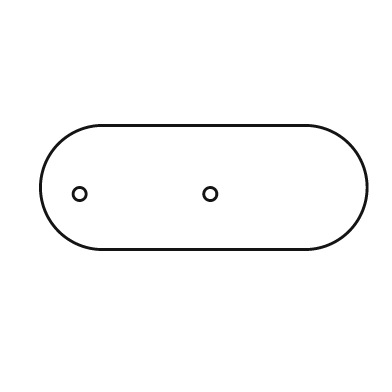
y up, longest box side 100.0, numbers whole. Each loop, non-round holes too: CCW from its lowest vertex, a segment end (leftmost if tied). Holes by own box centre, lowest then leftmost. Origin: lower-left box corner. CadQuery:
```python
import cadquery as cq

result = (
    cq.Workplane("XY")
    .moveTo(19.0, 0.0)
    .lineTo(81.0, 0.0)
    .threePointArc((100.0, 19.0), (81.0, 38.0))
    .lineTo(19.0, 38.0)
    .threePointArc((0.0, 19.0), (19.0, 0.0))
    .close()
    .moveTo(12.0, 17.0)
    .circle(2.0)
    .moveTo(52.0, 17.0)
    .circle(2.0)
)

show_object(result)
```